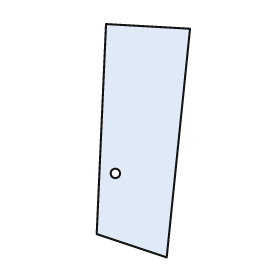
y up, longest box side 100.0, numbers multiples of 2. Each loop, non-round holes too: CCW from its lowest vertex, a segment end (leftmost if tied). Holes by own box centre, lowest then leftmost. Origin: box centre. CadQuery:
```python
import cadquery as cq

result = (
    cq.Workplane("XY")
    .moveTo(10.0, -50.0)
    .lineTo(20.0, 48.0)
    .lineTo(-16.0, 50.0)
    .lineTo(-20.0, -40.0)
    .close()
    .moveTo(-12.0, -14.0)
    .circle(2.0)
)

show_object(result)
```